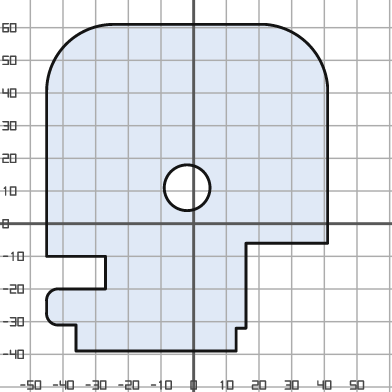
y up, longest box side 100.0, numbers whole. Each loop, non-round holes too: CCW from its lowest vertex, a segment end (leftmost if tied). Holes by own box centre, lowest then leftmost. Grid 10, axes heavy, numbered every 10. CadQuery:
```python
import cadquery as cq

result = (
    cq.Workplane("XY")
    .moveTo(-36.0, -39.0)
    .lineTo(13.0, -39.0)
    .lineTo(13.0, -32.0)
    .lineTo(16.0, -32.0)
    .lineTo(16.0, -6.0)
    .lineTo(41.0, -6.0)
    .lineTo(41.0, 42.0)
    .threePointArc((35.0, 55.0), (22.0, 61.0))
    .lineTo(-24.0, 61.0)
    .threePointArc((-39.0, 55.0), (-45.0, 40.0))
    .lineTo(-45.0, -10.0)
    .lineTo(-27.0, -10.0)
    .lineTo(-27.0, -20.0)
    .lineTo(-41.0, -20.0)
    .threePointArc((-44.0, -21.0), (-45.0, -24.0))
    .lineTo(-45.0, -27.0)
    .threePointArc((-44.0, -30.0), (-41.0, -31.0))
    .lineTo(-36.0, -31.0)
    .close()
    .moveTo(-2.0, 11.0)
    .circle(7.0)
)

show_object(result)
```